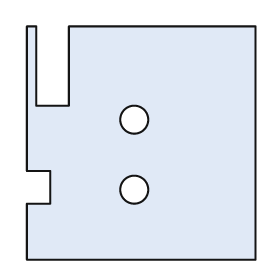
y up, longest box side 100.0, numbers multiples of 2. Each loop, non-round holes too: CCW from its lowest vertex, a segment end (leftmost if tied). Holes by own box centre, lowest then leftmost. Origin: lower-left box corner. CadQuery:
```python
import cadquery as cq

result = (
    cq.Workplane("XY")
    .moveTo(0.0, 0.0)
    .lineTo(98.0, 0.0)
    .lineTo(98.0, 100.0)
    .lineTo(18.0, 100.0)
    .lineTo(18.0, 66.0)
    .lineTo(4.0, 66.0)
    .lineTo(4.0, 100.0)
    .lineTo(0.0, 100.0)
    .lineTo(0.0, 38.0)
    .lineTo(10.0, 38.0)
    .lineTo(10.0, 24.0)
    .lineTo(0.0, 24.0)
    .close()
    .moveTo(46.0, 30.0)
    .circle(6.0)
    .moveTo(46.0, 60.0)
    .circle(6.0)
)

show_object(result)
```